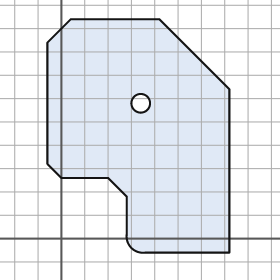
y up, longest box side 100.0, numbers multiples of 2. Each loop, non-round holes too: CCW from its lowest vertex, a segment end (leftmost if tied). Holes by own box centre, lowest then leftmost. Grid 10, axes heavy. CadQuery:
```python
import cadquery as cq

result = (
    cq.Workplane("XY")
    .moveTo(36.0, -6.0)
    .lineTo(72.0, -6.0)
    .lineTo(72.0, 64.0)
    .lineTo(42.0, 94.0)
    .lineTo(4.0, 94.0)
    .lineTo(-6.0, 84.0)
    .lineTo(-6.0, 32.0)
    .lineTo(0.0, 26.0)
    .lineTo(20.0, 26.0)
    .lineTo(28.0, 18.0)
    .lineTo(28.0, 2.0)
    .threePointArc((30.0, -4.0), (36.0, -6.0))
    .close()
    .moveTo(34.0, 58.0)
    .circle(4.0)
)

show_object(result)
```